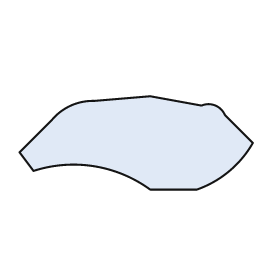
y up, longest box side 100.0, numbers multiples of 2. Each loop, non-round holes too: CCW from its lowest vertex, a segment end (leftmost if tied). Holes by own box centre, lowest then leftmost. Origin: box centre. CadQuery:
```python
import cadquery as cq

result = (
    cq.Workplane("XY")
    .moveTo(6.0, -20.0)
    .lineTo(26.0, -20.0)
    .threePointArc((40.0, -12.0), (50.0, 0.0))
    .lineTo(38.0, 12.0)
    .threePointArc((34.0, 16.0), (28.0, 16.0))
    .lineTo(6.0, 20.0)
    .lineTo(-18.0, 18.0)
    .threePointArc((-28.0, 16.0), (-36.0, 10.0))
    .lineTo(-50.0, -4.0)
    .lineTo(-44.0, -12.0)
    .threePointArc((-18.0, -10.0), (6.0, -20.0))
    .close()
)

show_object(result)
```